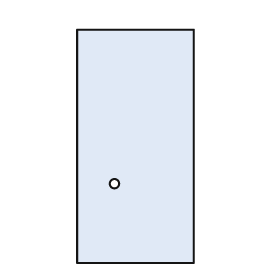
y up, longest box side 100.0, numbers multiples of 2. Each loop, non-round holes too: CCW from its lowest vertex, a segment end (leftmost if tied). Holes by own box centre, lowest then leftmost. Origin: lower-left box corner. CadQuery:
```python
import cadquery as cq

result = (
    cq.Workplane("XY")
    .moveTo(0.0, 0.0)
    .lineTo(50.0, 0.0)
    .lineTo(50.0, 100.0)
    .lineTo(0.0, 100.0)
    .close()
    .moveTo(16.0, 34.0)
    .circle(2.0)
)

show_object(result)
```